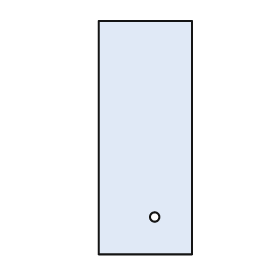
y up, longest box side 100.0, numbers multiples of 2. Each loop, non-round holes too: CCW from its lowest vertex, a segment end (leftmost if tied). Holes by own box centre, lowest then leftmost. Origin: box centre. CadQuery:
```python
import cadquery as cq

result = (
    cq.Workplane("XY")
    .moveTo(-20.0, -50.0)
    .lineTo(20.0, -50.0)
    .lineTo(20.0, 50.0)
    .lineTo(-20.0, 50.0)
    .close()
    .moveTo(4.0, -34.0)
    .circle(2.0)
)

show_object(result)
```